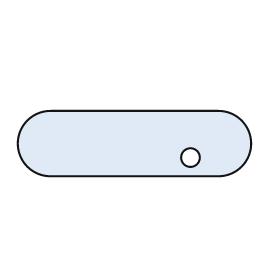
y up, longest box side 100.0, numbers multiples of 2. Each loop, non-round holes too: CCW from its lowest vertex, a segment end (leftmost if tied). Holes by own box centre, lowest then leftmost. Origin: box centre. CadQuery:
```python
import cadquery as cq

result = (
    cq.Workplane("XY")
    .moveTo(-36.0, -14.0)
    .lineTo(36.0, -14.0)
    .threePointArc((50.0, 0.0), (36.0, 14.0))
    .lineTo(-36.0, 14.0)
    .threePointArc((-50.0, 0.0), (-36.0, -14.0))
    .close()
    .moveTo(24.0, -6.0)
    .circle(4.0)
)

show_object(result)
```